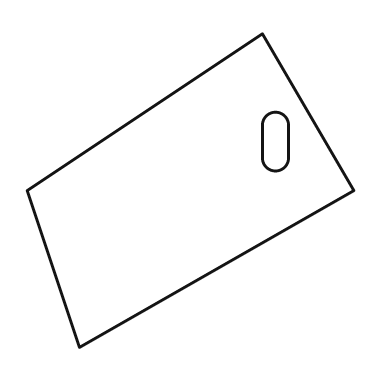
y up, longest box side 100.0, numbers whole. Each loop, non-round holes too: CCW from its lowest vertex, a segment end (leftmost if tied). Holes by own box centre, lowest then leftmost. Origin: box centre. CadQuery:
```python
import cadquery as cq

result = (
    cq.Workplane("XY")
    .moveTo(-34.0, -48.0)
    .lineTo(50.0, 0.0)
    .lineTo(22.0, 48.0)
    .lineTo(-50.0, 0.0)
    .close()
    .moveTo(22.0, 10.0)
    .threePointArc((26.0, 6.0), (30.0, 10.0))
    .lineTo(30.0, 20.0)
    .threePointArc((26.0, 24.0), (22.0, 20.0))
    .close()
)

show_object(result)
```